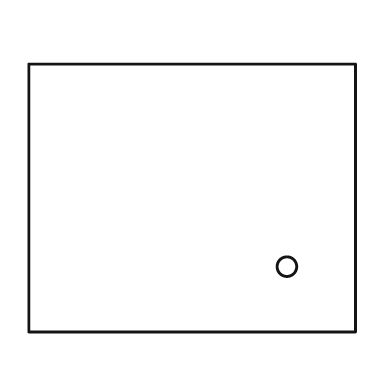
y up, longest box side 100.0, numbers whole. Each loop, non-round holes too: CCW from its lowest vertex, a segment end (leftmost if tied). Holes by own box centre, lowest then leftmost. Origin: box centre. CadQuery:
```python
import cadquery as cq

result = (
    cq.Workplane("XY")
    .moveTo(-50.0, -41.0)
    .lineTo(50.0, -41.0)
    .lineTo(50.0, 41.0)
    .lineTo(-50.0, 41.0)
    .close()
    .moveTo(29.0, -21.0)
    .circle(3.0)
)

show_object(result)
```